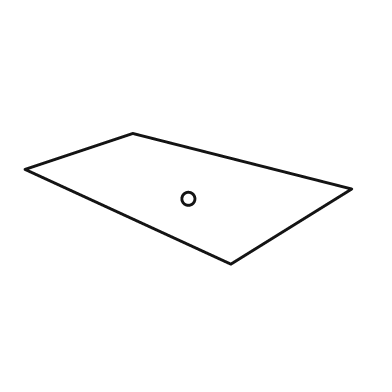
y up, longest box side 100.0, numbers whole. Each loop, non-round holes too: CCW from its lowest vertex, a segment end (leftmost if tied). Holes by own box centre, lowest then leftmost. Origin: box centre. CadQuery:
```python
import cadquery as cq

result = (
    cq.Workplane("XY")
    .moveTo(13.0, -20.0)
    .lineTo(50.0, 3.0)
    .lineTo(-17.0, 20.0)
    .lineTo(-50.0, 9.0)
    .close()
    .moveTo(0.0, 0.0)
    .circle(2.0)
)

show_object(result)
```